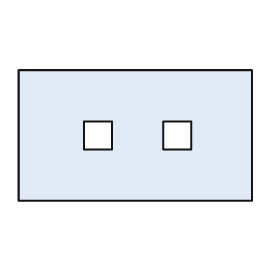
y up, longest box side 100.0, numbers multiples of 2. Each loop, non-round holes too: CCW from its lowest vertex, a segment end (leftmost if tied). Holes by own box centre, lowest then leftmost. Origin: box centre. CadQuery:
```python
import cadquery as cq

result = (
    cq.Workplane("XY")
    .moveTo(-50.0, -28.0)
    .lineTo(50.0, -28.0)
    .lineTo(50.0, 28.0)
    .lineTo(-50.0, 28.0)
    .close()
    .moveTo(-22.0, -6.0)
    .lineTo(-10.0, -6.0)
    .lineTo(-10.0, 6.0)
    .lineTo(-22.0, 6.0)
    .close()
    .moveTo(12.0, -6.0)
    .lineTo(24.0, -6.0)
    .lineTo(24.0, 6.0)
    .lineTo(12.0, 6.0)
    .close()
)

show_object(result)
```